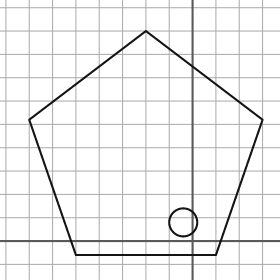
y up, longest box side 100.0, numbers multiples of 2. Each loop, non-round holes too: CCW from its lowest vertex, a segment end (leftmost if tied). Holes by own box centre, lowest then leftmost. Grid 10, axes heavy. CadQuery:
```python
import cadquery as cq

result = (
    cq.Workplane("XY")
    .moveTo(-50.0, -6.0)
    .lineTo(10.0, -6.0)
    .lineTo(30.0, 52.0)
    .lineTo(-20.0, 90.0)
    .lineTo(-70.0, 52.0)
    .close()
    .moveTo(-4.0, 8.0)
    .circle(6.0)
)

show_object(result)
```